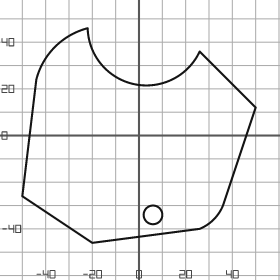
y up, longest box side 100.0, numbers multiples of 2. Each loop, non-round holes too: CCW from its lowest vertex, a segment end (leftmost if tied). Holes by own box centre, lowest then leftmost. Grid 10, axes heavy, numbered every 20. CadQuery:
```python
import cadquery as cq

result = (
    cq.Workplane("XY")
    .moveTo(-20.0, -46.0)
    .lineTo(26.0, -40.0)
    .threePointArc((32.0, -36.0), (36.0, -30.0))
    .lineTo(50.0, 12.0)
    .lineTo(26.0, 36.0)
    .threePointArc((-2.0, 22.0), (-22.0, 46.0))
    .threePointArc((-36.0, 38.0), (-44.0, 24.0))
    .lineTo(-50.0, -26.0)
    .close()
    .moveTo(6.0, -34.0)
    .circle(4.0)
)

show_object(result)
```